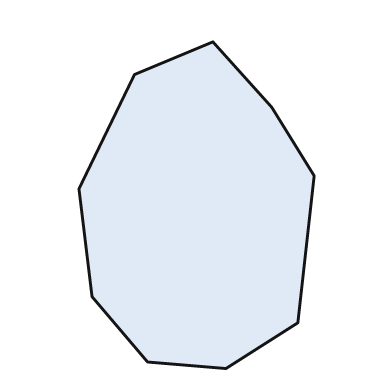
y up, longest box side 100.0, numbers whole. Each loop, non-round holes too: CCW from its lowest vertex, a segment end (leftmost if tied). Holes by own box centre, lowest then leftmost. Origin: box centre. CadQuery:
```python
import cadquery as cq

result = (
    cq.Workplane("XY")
    .moveTo(9.0, -50.0)
    .lineTo(31.0, -36.0)
    .lineTo(36.0, 9.0)
    .lineTo(23.0, 30.0)
    .lineTo(5.0, 50.0)
    .lineTo(-19.0, 40.0)
    .lineTo(-36.0, 5.0)
    .lineTo(-32.0, -28.0)
    .lineTo(-15.0, -48.0)
    .close()
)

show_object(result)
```